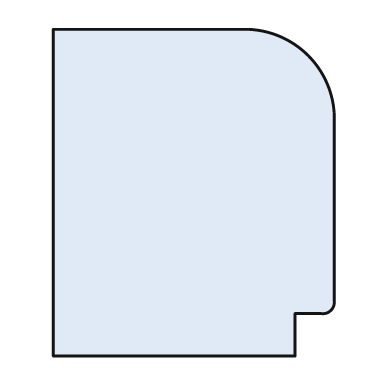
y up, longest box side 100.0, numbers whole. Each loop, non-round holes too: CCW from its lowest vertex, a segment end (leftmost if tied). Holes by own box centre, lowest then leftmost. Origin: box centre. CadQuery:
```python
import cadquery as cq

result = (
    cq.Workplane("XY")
    .moveTo(-43.0, -50.0)
    .lineTo(31.0, -50.0)
    .lineTo(31.0, -37.0)
    .lineTo(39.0, -37.0)
    .threePointArc((42.0, -36.0), (43.0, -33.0))
    .lineTo(43.0, 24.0)
    .threePointArc((35.0, 42.0), (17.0, 50.0))
    .lineTo(-43.0, 50.0)
    .close()
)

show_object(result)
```